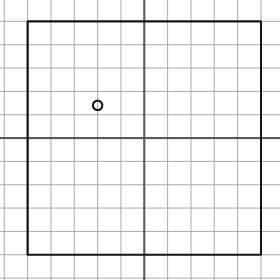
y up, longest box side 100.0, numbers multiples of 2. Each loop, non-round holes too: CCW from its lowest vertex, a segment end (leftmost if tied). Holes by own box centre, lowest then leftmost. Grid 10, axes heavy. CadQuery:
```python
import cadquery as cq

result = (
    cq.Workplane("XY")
    .moveTo(-50.0, -50.0)
    .lineTo(50.0, -50.0)
    .lineTo(50.0, 50.0)
    .lineTo(-50.0, 50.0)
    .close()
    .moveTo(-20.0, 14.0)
    .circle(2.0)
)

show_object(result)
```